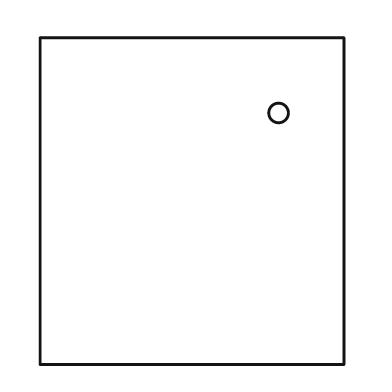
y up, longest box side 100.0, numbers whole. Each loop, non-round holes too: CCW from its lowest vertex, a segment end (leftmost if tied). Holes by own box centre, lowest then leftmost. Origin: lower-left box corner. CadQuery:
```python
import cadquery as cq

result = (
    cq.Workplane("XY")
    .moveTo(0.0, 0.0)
    .lineTo(93.0, 0.0)
    .lineTo(93.0, 100.0)
    .lineTo(0.0, 100.0)
    .close()
    .moveTo(73.0, 77.0)
    .circle(3.0)
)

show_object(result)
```